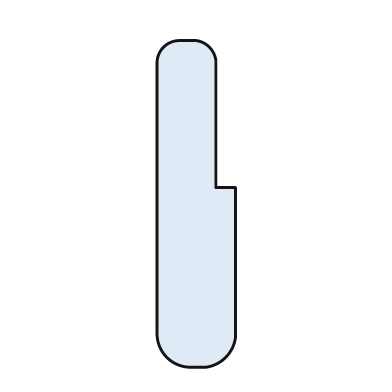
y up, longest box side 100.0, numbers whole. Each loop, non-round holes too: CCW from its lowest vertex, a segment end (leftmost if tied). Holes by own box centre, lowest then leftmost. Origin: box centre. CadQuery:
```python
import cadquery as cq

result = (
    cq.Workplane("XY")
    .moveTo(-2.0, -50.0)
    .lineTo(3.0, -50.0)
    .threePointArc((9.0, -47.0), (12.0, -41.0))
    .lineTo(12.0, 5.0)
    .lineTo(6.0, 5.0)
    .lineTo(6.0, 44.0)
    .threePointArc((4.0, 48.0), (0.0, 50.0))
    .lineTo(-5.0, 50.0)
    .threePointArc((-10.0, 48.0), (-12.0, 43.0))
    .lineTo(-12.0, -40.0)
    .threePointArc((-9.0, -47.0), (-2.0, -50.0))
    .close()
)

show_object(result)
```